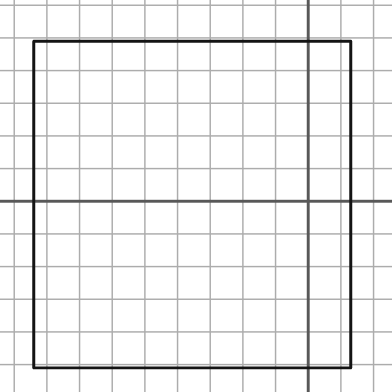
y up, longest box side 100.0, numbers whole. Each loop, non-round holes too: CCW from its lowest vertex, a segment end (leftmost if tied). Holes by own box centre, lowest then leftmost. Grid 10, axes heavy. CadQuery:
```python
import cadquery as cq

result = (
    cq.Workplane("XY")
    .moveTo(-84.0, -51.0)
    .lineTo(13.0, -51.0)
    .lineTo(13.0, 49.0)
    .lineTo(-84.0, 49.0)
    .close()
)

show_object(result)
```